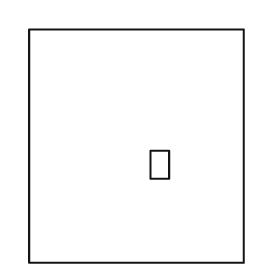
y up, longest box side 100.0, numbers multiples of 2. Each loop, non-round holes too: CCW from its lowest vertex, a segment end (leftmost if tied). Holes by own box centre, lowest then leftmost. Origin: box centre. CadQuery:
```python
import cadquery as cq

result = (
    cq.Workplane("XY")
    .moveTo(-46.0, -50.0)
    .lineTo(46.0, -50.0)
    .lineTo(46.0, 50.0)
    .lineTo(-46.0, 50.0)
    .close()
    .moveTo(6.0, -14.0)
    .lineTo(14.0, -14.0)
    .lineTo(14.0, -2.0)
    .lineTo(6.0, -2.0)
    .close()
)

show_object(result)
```